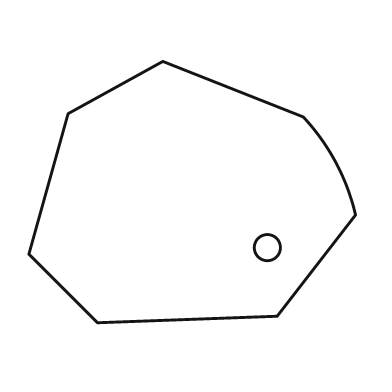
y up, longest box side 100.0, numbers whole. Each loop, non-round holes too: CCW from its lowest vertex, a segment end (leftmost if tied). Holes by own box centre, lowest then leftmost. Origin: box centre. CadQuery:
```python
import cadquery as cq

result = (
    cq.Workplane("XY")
    .moveTo(-29.0, -40.0)
    .lineTo(26.0, -38.0)
    .lineTo(50.0, -7.0)
    .threePointArc((44.0, 9.0), (34.0, 23.0))
    .lineTo(-9.0, 40.0)
    .lineTo(-38.0, 24.0)
    .lineTo(-50.0, -19.0)
    .close()
    .moveTo(23.0, -17.0)
    .circle(4.0)
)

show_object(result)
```